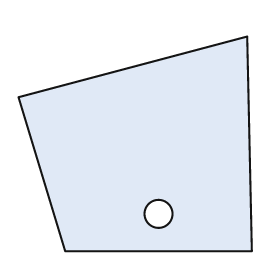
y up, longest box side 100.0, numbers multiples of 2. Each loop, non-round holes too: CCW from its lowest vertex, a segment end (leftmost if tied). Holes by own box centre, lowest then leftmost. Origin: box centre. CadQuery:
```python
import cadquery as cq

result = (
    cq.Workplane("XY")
    .moveTo(-30.0, -46.0)
    .lineTo(50.0, -46.0)
    .lineTo(48.0, 46.0)
    .lineTo(-50.0, 20.0)
    .close()
    .moveTo(10.0, -30.0)
    .circle(6.0)
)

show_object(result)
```